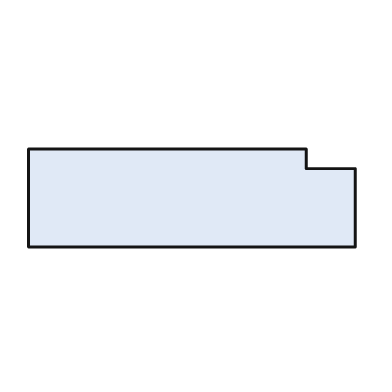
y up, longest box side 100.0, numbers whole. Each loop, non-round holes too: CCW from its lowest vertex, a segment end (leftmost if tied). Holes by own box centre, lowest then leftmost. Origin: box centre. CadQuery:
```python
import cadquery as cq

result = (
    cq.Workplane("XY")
    .moveTo(-50.0, -15.0)
    .lineTo(50.0, -15.0)
    .lineTo(50.0, 9.0)
    .lineTo(35.0, 9.0)
    .lineTo(35.0, 15.0)
    .lineTo(-50.0, 15.0)
    .close()
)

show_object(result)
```